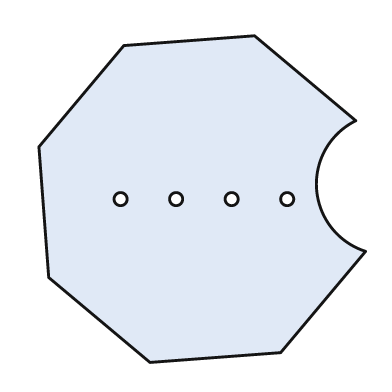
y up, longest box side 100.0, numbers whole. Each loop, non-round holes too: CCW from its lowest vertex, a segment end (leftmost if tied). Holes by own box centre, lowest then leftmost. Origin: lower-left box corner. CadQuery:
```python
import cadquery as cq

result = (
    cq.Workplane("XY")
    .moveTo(34.0, 0.0)
    .lineTo(74.0, 3.0)
    .lineTo(100.0, 34.0)
    .threePointArc((85.0, 53.0), (97.0, 74.0))
    .lineTo(66.0, 100.0)
    .lineTo(26.0, 97.0)
    .lineTo(0.0, 66.0)
    .lineTo(3.0, 26.0)
    .close()
    .moveTo(25.0, 50.0)
    .circle(2.0)
    .moveTo(42.0, 50.0)
    .circle(2.0)
    .moveTo(59.0, 50.0)
    .circle(2.0)
    .moveTo(76.0, 50.0)
    .circle(2.0)
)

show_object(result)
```